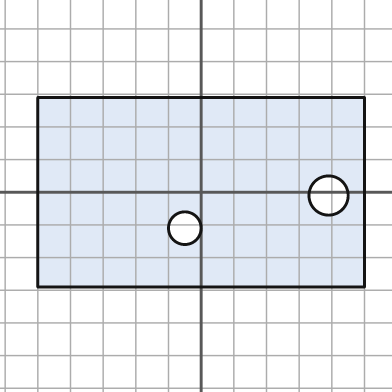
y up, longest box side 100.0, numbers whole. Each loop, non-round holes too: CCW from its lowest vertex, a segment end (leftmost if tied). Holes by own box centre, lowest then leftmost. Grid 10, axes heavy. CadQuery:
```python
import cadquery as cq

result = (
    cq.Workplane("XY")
    .moveTo(-50.0, -29.0)
    .lineTo(50.0, -29.0)
    .lineTo(50.0, 29.0)
    .lineTo(-50.0, 29.0)
    .close()
    .moveTo(-5.0, -11.0)
    .circle(5.0)
    .moveTo(39.0, -1.0)
    .circle(6.0)
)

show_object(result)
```